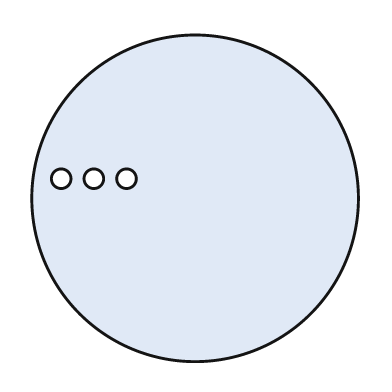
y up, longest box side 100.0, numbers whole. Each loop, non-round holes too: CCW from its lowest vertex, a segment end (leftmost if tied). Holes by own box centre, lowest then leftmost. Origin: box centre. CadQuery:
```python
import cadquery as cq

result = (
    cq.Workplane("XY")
    .moveTo(0.0, 0.0)
    .circle(50.0)
    .moveTo(-41.0, 6.0)
    .circle(3.0)
    .moveTo(-31.0, 6.0)
    .circle(3.0)
    .moveTo(-21.0, 6.0)
    .circle(3.0)
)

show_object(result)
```